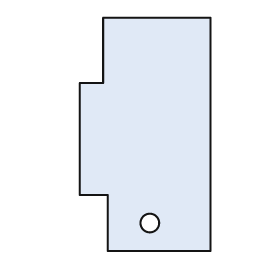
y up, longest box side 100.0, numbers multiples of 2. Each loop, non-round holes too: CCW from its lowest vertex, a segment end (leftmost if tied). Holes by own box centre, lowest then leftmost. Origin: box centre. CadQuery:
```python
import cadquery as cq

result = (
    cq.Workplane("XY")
    .moveTo(-16.0, -50.0)
    .lineTo(28.0, -50.0)
    .lineTo(28.0, 50.0)
    .lineTo(-18.0, 50.0)
    .lineTo(-18.0, 22.0)
    .lineTo(-28.0, 22.0)
    .lineTo(-28.0, -26.0)
    .lineTo(-16.0, -26.0)
    .close()
    .moveTo(2.0, -38.0)
    .circle(4.0)
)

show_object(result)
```